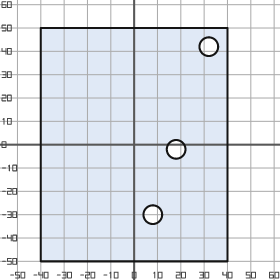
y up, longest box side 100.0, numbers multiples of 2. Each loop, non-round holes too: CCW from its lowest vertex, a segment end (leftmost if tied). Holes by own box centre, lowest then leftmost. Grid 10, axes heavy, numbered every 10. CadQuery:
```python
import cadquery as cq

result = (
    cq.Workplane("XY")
    .moveTo(-40.0, -50.0)
    .lineTo(40.0, -50.0)
    .lineTo(40.0, 50.0)
    .lineTo(-40.0, 50.0)
    .close()
    .moveTo(8.0, -30.0)
    .circle(4.0)
    .moveTo(18.0, -2.0)
    .circle(4.0)
    .moveTo(32.0, 42.0)
    .circle(4.0)
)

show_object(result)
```